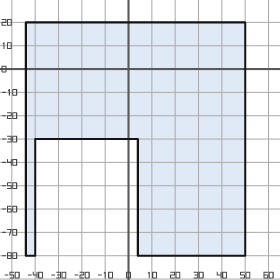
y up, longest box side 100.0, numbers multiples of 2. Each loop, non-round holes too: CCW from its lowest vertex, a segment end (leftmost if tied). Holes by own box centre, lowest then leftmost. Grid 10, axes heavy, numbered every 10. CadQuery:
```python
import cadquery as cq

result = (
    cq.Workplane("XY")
    .moveTo(-44.0, -80.0)
    .lineTo(-40.0, -80.0)
    .lineTo(-40.0, -30.0)
    .lineTo(4.0, -30.0)
    .lineTo(4.0, -80.0)
    .lineTo(50.0, -80.0)
    .lineTo(50.0, 20.0)
    .lineTo(-44.0, 20.0)
    .close()
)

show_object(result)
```